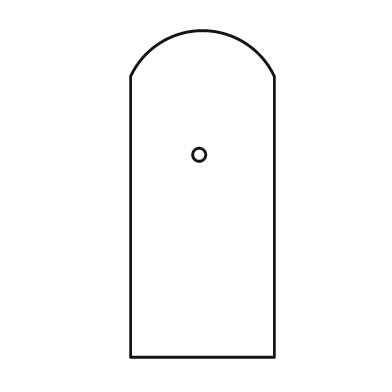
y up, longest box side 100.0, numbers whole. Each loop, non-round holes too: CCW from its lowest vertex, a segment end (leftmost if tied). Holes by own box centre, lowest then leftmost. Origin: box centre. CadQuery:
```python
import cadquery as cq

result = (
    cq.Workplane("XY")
    .moveTo(-22.0, -50.0)
    .lineTo(22.0, -50.0)
    .lineTo(22.0, 36.0)
    .threePointArc((0.0, 50.0), (-22.0, 36.0))
    .close()
    .moveTo(-1.0, 12.0)
    .circle(2.0)
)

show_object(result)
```